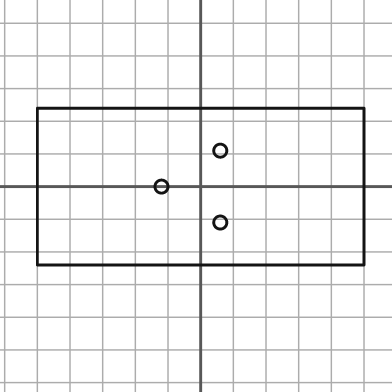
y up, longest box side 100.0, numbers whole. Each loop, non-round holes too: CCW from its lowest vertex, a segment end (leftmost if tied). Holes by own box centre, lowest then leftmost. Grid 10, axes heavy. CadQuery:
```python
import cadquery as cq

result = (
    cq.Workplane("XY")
    .moveTo(-50.0, -24.0)
    .lineTo(50.0, -24.0)
    .lineTo(50.0, 24.0)
    .lineTo(-50.0, 24.0)
    .close()
    .moveTo(6.0, -11.0)
    .circle(2.0)
    .moveTo(-12.0, 0.0)
    .circle(2.0)
    .moveTo(6.0, 11.0)
    .circle(2.0)
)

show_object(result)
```